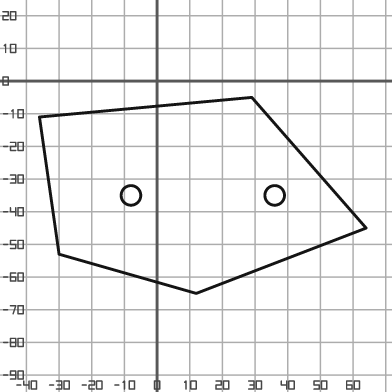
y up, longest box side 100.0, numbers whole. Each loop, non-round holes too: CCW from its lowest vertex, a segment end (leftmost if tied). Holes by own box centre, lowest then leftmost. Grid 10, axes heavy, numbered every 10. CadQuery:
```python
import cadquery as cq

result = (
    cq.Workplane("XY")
    .moveTo(12.0, -65.0)
    .lineTo(64.0, -45.0)
    .lineTo(29.0, -5.0)
    .lineTo(-36.0, -11.0)
    .lineTo(-30.0, -53.0)
    .close()
    .moveTo(-8.0, -35.0)
    .circle(3.0)
    .moveTo(36.0, -35.0)
    .circle(3.0)
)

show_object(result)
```